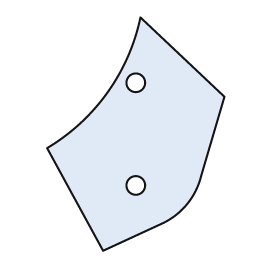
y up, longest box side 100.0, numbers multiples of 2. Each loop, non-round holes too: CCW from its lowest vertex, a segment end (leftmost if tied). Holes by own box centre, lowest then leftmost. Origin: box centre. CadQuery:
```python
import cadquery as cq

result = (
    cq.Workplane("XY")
    .moveTo(-14.0, -50.0)
    .lineTo(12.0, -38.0)
    .threePointArc((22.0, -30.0), (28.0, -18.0))
    .lineTo(38.0, 16.0)
    .lineTo(2.0, 50.0)
    .threePointArc((-12.0, 18.0), (-38.0, -6.0))
    .close()
    .moveTo(0.0, -22.0)
    .circle(4.0)
    .moveTo(0.0, 22.0)
    .circle(4.0)
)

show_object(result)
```